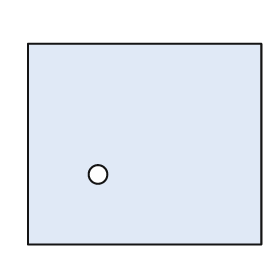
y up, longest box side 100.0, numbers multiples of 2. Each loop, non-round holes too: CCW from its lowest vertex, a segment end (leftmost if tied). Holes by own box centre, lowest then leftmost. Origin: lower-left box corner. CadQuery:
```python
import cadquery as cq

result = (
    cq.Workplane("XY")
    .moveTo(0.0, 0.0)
    .lineTo(100.0, 0.0)
    .lineTo(100.0, 86.0)
    .lineTo(0.0, 86.0)
    .close()
    .moveTo(30.0, 30.0)
    .circle(4.0)
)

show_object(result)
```